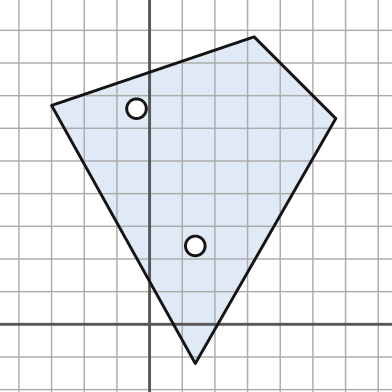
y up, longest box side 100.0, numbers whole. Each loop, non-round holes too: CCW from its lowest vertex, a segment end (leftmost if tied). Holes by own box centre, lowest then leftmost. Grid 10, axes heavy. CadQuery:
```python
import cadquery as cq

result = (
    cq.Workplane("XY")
    .moveTo(14.0, -12.0)
    .lineTo(57.0, 63.0)
    .lineTo(32.0, 88.0)
    .lineTo(-30.0, 67.0)
    .close()
    .moveTo(14.0, 24.0)
    .circle(3.0)
    .moveTo(-4.0, 66.0)
    .circle(3.0)
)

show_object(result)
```